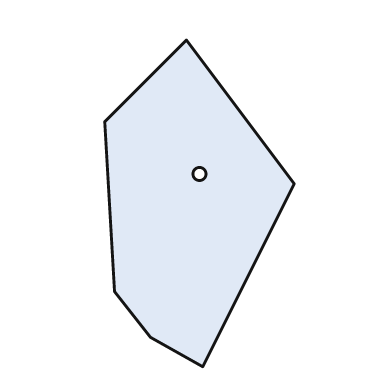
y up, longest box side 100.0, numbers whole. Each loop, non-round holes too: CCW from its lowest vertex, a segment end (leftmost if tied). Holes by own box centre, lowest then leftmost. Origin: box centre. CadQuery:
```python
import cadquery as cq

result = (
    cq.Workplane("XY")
    .moveTo(1.0, -50.0)
    .lineTo(29.0, 6.0)
    .lineTo(-4.0, 50.0)
    .lineTo(-29.0, 25.0)
    .lineTo(-26.0, -27.0)
    .lineTo(-15.0, -41.0)
    .close()
    .moveTo(0.0, 9.0)
    .circle(2.0)
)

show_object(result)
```